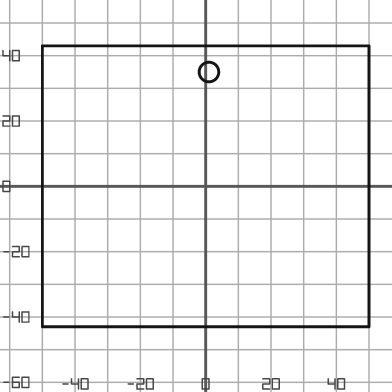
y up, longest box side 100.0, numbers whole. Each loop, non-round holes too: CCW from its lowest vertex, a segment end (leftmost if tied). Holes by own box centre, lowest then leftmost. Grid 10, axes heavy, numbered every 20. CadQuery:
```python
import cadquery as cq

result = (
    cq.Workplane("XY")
    .moveTo(-50.0, -43.0)
    .lineTo(50.0, -43.0)
    .lineTo(50.0, 43.0)
    .lineTo(-50.0, 43.0)
    .close()
    .moveTo(1.0, 35.0)
    .circle(3.0)
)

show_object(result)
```